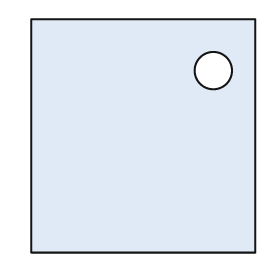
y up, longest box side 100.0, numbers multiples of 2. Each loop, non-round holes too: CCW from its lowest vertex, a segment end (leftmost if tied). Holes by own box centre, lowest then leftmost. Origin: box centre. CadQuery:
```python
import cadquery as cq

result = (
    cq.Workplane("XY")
    .moveTo(-48.0, -50.0)
    .lineTo(48.0, -50.0)
    .lineTo(48.0, 50.0)
    .lineTo(-48.0, 50.0)
    .close()
    .moveTo(30.0, 28.0)
    .circle(8.0)
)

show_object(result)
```